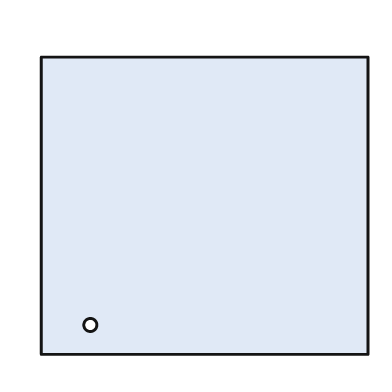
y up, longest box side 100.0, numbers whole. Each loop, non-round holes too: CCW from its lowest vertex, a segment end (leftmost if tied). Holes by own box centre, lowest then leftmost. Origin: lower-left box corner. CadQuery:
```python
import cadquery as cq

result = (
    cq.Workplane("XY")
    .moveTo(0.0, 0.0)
    .lineTo(100.0, 0.0)
    .lineTo(100.0, 91.0)
    .lineTo(0.0, 91.0)
    .close()
    .moveTo(15.0, 9.0)
    .circle(2.0)
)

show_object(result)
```